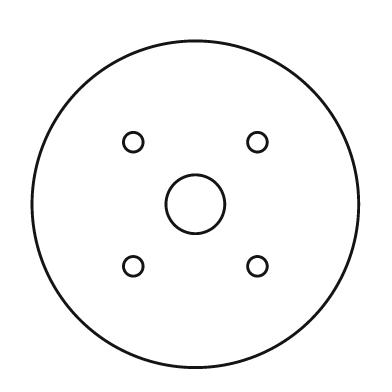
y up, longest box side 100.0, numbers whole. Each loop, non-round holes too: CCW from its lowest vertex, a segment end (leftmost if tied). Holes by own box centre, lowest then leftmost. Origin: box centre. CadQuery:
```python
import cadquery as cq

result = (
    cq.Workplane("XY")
    .moveTo(0.0, 0.0)
    .circle(50.0)
    .moveTo(-19.0, -19.0)
    .circle(3.0)
    .moveTo(19.0, -19.0)
    .circle(3.0)
    .moveTo(0.0, 0.0)
    .circle(9.0)
    .moveTo(-19.0, 19.0)
    .circle(3.0)
    .moveTo(19.0, 19.0)
    .circle(3.0)
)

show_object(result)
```